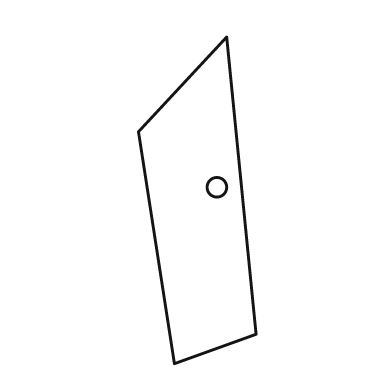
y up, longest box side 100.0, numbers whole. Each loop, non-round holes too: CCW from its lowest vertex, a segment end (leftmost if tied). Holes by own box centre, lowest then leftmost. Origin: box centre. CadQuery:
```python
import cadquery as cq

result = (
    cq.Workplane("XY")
    .moveTo(-7.0, -50.0)
    .lineTo(18.0, -41.0)
    .lineTo(9.0, 50.0)
    .lineTo(-18.0, 21.0)
    .close()
    .moveTo(6.0, 4.0)
    .circle(3.0)
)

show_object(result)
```